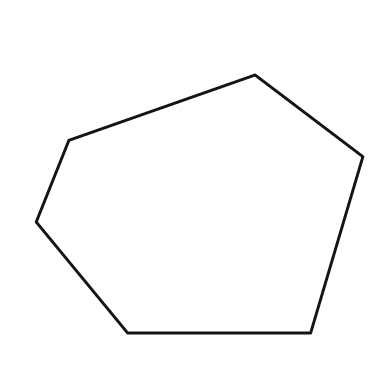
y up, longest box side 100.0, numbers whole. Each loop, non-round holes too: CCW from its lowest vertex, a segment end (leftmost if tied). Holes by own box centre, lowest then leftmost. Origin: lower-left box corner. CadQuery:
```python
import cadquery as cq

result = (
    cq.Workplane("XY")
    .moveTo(28.0, 0.0)
    .lineTo(84.0, 0.0)
    .lineTo(100.0, 54.0)
    .lineTo(67.0, 79.0)
    .lineTo(10.0, 59.0)
    .lineTo(0.0, 34.0)
    .close()
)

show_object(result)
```